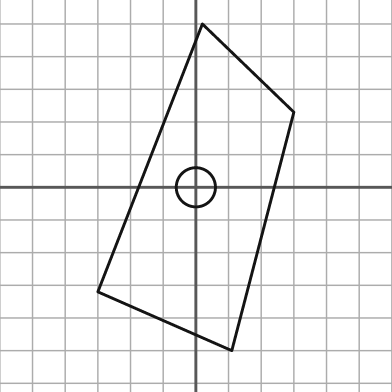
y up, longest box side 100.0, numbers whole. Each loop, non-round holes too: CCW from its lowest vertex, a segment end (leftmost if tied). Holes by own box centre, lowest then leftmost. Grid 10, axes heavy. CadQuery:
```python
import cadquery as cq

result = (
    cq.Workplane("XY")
    .moveTo(11.0, -50.0)
    .lineTo(30.0, 23.0)
    .lineTo(2.0, 50.0)
    .lineTo(-30.0, -32.0)
    .close()
    .moveTo(0.0, 0.0)
    .circle(6.0)
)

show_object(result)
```